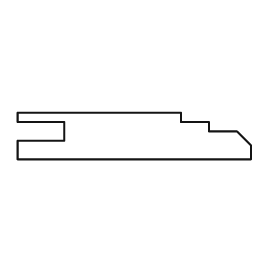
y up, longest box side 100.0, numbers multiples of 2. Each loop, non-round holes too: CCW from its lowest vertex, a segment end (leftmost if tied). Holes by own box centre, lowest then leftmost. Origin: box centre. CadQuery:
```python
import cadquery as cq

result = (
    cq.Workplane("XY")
    .moveTo(-50.0, -10.0)
    .lineTo(50.0, -10.0)
    .lineTo(50.0, -4.0)
    .lineTo(44.0, 2.0)
    .lineTo(32.0, 2.0)
    .lineTo(32.0, 6.0)
    .lineTo(20.0, 6.0)
    .lineTo(20.0, 10.0)
    .lineTo(-50.0, 10.0)
    .lineTo(-50.0, 6.0)
    .lineTo(-30.0, 6.0)
    .lineTo(-30.0, -2.0)
    .lineTo(-50.0, -2.0)
    .close()
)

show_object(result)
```